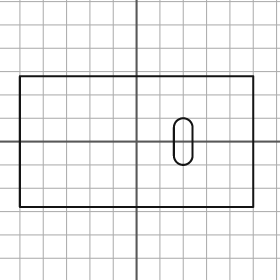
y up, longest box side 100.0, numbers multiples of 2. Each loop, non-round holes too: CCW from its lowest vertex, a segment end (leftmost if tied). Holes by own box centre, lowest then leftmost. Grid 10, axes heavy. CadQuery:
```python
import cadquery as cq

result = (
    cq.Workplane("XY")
    .moveTo(-50.0, -28.0)
    .lineTo(50.0, -28.0)
    .lineTo(50.0, 28.0)
    .lineTo(-50.0, 28.0)
    .close()
    .moveTo(16.0, -6.0)
    .threePointArc((20.0, -10.0), (24.0, -6.0))
    .lineTo(24.0, 6.0)
    .threePointArc((20.0, 10.0), (16.0, 6.0))
    .close()
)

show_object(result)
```